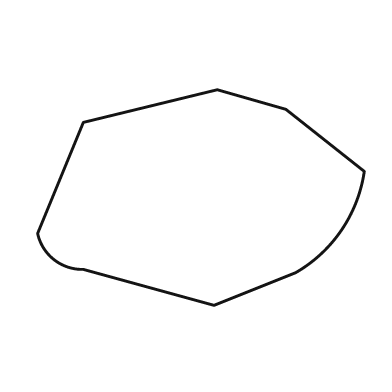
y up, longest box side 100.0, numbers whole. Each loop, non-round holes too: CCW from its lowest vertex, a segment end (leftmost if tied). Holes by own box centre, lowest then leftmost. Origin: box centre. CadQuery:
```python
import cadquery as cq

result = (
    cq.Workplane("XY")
    .moveTo(4.0, -33.0)
    .lineTo(29.0, -23.0)
    .threePointArc((43.0, -10.0), (50.0, 8.0))
    .lineTo(26.0, 27.0)
    .lineTo(5.0, 33.0)
    .lineTo(-36.0, 23.0)
    .lineTo(-50.0, -11.0)
    .threePointArc((-45.0, -19.0), (-36.0, -22.0))
    .close()
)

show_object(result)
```